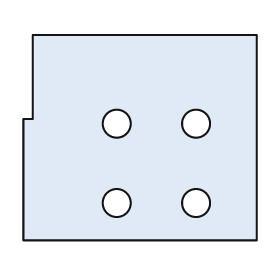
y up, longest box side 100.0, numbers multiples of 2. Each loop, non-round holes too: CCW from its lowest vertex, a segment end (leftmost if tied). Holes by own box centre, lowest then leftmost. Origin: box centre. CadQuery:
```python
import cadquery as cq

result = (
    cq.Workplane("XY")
    .moveTo(-50.0, -44.0)
    .lineTo(50.0, -44.0)
    .lineTo(50.0, 44.0)
    .lineTo(-46.0, 44.0)
    .lineTo(-46.0, 8.0)
    .lineTo(-50.0, 8.0)
    .close()
    .moveTo(-10.0, -28.0)
    .circle(6.0)
    .moveTo(24.0, -28.0)
    .circle(6.0)
    .moveTo(-10.0, 6.0)
    .circle(6.0)
    .moveTo(24.0, 6.0)
    .circle(6.0)
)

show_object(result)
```